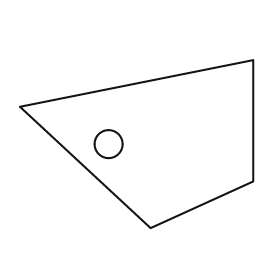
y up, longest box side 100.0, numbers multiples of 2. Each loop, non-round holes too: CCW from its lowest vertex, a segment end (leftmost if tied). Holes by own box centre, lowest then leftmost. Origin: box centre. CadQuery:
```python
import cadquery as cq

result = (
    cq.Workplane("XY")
    .moveTo(6.0, -36.0)
    .lineTo(50.0, -16.0)
    .lineTo(50.0, 36.0)
    .lineTo(-50.0, 16.0)
    .close()
    .moveTo(-12.0, 0.0)
    .circle(6.0)
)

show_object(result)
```